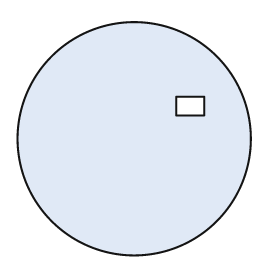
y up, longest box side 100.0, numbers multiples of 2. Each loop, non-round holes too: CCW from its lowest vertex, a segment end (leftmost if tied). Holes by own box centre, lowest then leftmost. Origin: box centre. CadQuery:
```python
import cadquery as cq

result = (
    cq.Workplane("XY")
    .moveTo(0.0, 0.0)
    .circle(50.0)
    .moveTo(18.0, 10.0)
    .lineTo(30.0, 10.0)
    .lineTo(30.0, 18.0)
    .lineTo(18.0, 18.0)
    .close()
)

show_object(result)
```